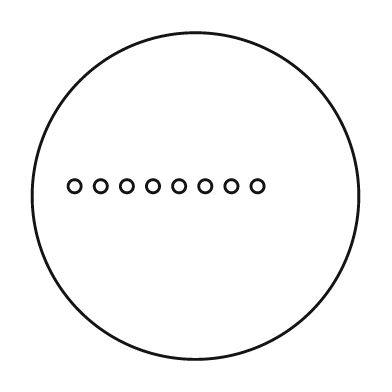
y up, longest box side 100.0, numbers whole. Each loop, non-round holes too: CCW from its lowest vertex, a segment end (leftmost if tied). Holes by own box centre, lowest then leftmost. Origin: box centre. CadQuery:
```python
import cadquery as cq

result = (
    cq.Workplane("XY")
    .moveTo(0.0, 0.0)
    .circle(50.0)
    .moveTo(-37.0, 3.0)
    .circle(2.0)
    .moveTo(-29.0, 3.0)
    .circle(2.0)
    .moveTo(-21.0, 3.0)
    .circle(2.0)
    .moveTo(-13.0, 3.0)
    .circle(2.0)
    .moveTo(-5.0, 3.0)
    .circle(2.0)
    .moveTo(3.0, 3.0)
    .circle(2.0)
    .moveTo(11.0, 3.0)
    .circle(2.0)
    .moveTo(19.0, 3.0)
    .circle(2.0)
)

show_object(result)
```